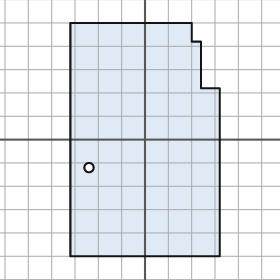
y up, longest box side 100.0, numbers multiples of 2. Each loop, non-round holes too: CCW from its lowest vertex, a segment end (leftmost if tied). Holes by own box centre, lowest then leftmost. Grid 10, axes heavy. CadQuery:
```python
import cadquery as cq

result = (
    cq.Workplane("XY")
    .moveTo(-32.0, -50.0)
    .lineTo(32.0, -50.0)
    .lineTo(32.0, 22.0)
    .lineTo(24.0, 22.0)
    .lineTo(24.0, 42.0)
    .lineTo(20.0, 42.0)
    .lineTo(20.0, 50.0)
    .lineTo(-32.0, 50.0)
    .close()
    .moveTo(-24.0, -12.0)
    .circle(2.0)
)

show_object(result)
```